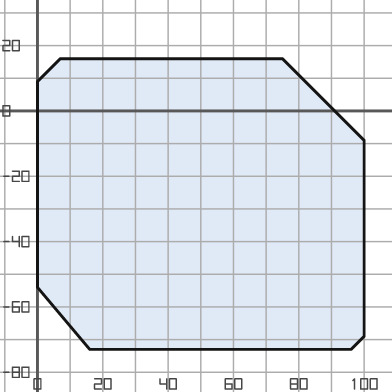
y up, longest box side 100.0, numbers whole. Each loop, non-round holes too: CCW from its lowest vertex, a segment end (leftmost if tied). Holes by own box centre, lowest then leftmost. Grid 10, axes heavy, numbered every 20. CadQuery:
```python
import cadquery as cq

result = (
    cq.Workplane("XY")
    .moveTo(16.0, -73.0)
    .lineTo(96.0, -73.0)
    .lineTo(100.0, -69.0)
    .lineTo(100.0, -9.0)
    .lineTo(75.0, 16.0)
    .lineTo(7.0, 16.0)
    .lineTo(0.0, 9.0)
    .lineTo(0.0, -54.0)
    .close()
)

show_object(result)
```